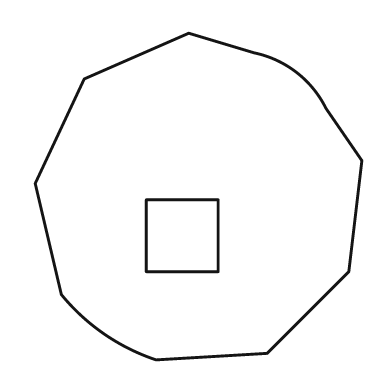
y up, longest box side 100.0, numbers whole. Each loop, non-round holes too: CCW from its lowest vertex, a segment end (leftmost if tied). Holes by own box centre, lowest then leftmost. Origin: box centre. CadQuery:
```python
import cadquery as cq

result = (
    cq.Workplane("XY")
    .moveTo(-13.0, -50.0)
    .lineTo(21.0, -48.0)
    .lineTo(46.0, -23.0)
    .lineTo(50.0, 11.0)
    .lineTo(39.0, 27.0)
    .threePointArc((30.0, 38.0), (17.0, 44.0))
    .lineTo(-3.0, 50.0)
    .lineTo(-35.0, 36.0)
    .lineTo(-50.0, 4.0)
    .lineTo(-42.0, -30.0)
    .threePointArc((-29.0, -42.0), (-13.0, -50.0))
    .close()
    .moveTo(-16.0, -23.0)
    .lineTo(6.0, -23.0)
    .lineTo(6.0, -1.0)
    .lineTo(-16.0, -1.0)
    .close()
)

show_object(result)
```